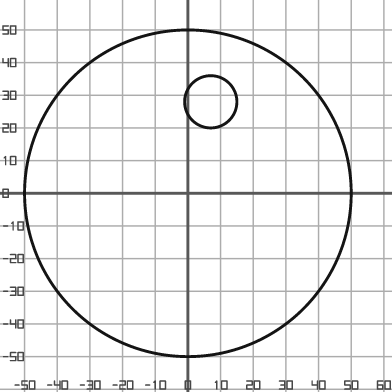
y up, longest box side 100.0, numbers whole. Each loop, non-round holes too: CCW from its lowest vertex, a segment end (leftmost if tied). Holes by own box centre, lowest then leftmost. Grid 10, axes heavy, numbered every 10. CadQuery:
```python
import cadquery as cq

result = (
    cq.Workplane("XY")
    .moveTo(0.0, 0.0)
    .circle(50.0)
    .moveTo(7.0, 28.0)
    .circle(8.0)
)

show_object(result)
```